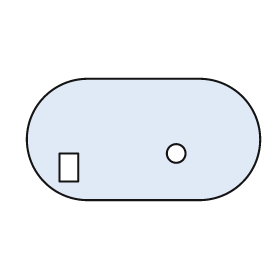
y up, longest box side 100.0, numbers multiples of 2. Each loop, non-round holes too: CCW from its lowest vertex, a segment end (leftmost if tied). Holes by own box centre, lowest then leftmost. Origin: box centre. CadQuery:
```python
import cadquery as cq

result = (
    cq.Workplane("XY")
    .moveTo(-24.0, -26.0)
    .lineTo(24.0, -26.0)
    .threePointArc((50.0, 0.0), (24.0, 26.0))
    .lineTo(-24.0, 26.0)
    .threePointArc((-50.0, 0.0), (-24.0, -26.0))
    .close()
    .moveTo(-36.0, -18.0)
    .lineTo(-28.0, -18.0)
    .lineTo(-28.0, -6.0)
    .lineTo(-36.0, -6.0)
    .close()
    .moveTo(14.0, -6.0)
    .circle(4.0)
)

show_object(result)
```